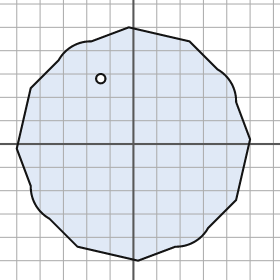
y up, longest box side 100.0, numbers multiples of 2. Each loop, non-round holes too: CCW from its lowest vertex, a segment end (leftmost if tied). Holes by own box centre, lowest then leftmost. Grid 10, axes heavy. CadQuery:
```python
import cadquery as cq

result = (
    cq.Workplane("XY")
    .moveTo(2.0, -50.0)
    .lineTo(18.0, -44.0)
    .threePointArc((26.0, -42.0), (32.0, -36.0))
    .lineTo(44.0, -24.0)
    .lineTo(50.0, 2.0)
    .lineTo(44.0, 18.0)
    .threePointArc((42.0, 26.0), (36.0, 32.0))
    .lineTo(24.0, 44.0)
    .lineTo(-2.0, 50.0)
    .lineTo(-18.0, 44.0)
    .threePointArc((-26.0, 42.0), (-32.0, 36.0))
    .lineTo(-44.0, 24.0)
    .lineTo(-50.0, -2.0)
    .lineTo(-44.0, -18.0)
    .threePointArc((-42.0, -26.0), (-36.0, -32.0))
    .lineTo(-24.0, -44.0)
    .close()
    .moveTo(-14.0, 28.0)
    .circle(2.0)
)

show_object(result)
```